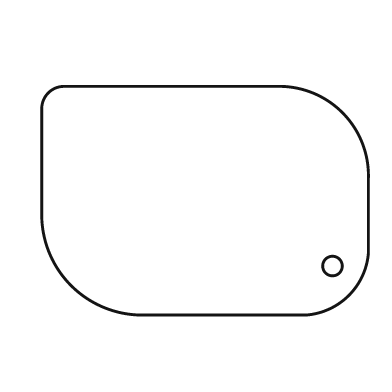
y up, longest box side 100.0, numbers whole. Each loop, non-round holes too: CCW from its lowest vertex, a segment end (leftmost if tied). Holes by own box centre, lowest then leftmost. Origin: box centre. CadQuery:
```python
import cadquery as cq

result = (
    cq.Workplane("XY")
    .moveTo(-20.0, -35.0)
    .lineTo(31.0, -35.0)
    .threePointArc((44.0, -29.0), (50.0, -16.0))
    .lineTo(50.0, 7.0)
    .threePointArc((42.0, 27.0), (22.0, 35.0))
    .lineTo(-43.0, 35.0)
    .threePointArc((-48.0, 33.0), (-50.0, 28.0))
    .lineTo(-50.0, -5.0)
    .threePointArc((-41.0, -26.0), (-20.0, -35.0))
    .close()
    .moveTo(39.0, -20.0)
    .circle(3.0)
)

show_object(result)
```